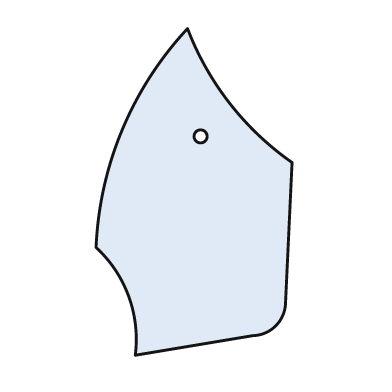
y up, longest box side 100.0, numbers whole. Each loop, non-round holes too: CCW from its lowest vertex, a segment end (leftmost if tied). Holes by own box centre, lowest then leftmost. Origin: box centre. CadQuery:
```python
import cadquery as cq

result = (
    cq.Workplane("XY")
    .moveTo(-18.0, -50.0)
    .lineTo(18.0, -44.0)
    .threePointArc((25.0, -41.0), (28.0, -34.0))
    .lineTo(30.0, 9.0)
    .threePointArc((11.0, 27.0), (-2.0, 50.0))
    .threePointArc((-22.0, 19.0), (-30.0, -17.0))
    .threePointArc((-20.0, -32.0), (-18.0, -50.0))
    .close()
    .moveTo(2.0, 17.0)
    .circle(2.0)
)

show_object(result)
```